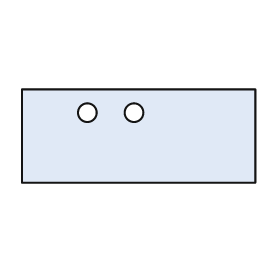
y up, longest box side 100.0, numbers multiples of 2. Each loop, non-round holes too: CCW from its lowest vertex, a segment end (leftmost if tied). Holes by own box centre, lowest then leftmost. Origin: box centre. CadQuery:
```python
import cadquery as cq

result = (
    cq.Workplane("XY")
    .moveTo(-50.0, -20.0)
    .lineTo(50.0, -20.0)
    .lineTo(50.0, 20.0)
    .lineTo(-50.0, 20.0)
    .close()
    .moveTo(-22.0, 10.0)
    .circle(4.0)
    .moveTo(-2.0, 10.0)
    .circle(4.0)
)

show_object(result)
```